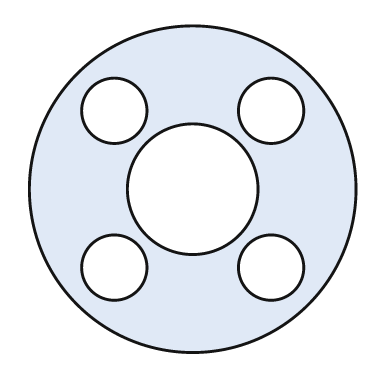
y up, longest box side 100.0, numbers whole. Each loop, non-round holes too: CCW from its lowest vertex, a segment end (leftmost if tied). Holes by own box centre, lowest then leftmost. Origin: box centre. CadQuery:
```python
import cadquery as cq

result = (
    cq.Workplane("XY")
    .moveTo(0.0, 0.0)
    .circle(50.0)
    .moveTo(-24.0, -24.0)
    .circle(10.0)
    .moveTo(24.0, -24.0)
    .circle(10.0)
    .moveTo(0.0, 0.0)
    .circle(20.0)
    .moveTo(-24.0, 24.0)
    .circle(10.0)
    .moveTo(24.0, 24.0)
    .circle(10.0)
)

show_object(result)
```